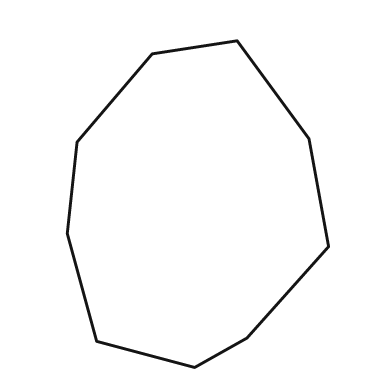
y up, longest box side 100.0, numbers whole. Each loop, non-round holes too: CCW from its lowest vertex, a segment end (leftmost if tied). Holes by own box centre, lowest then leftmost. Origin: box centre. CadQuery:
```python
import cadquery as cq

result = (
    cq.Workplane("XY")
    .moveTo(-1.0, -50.0)
    .lineTo(15.0, -41.0)
    .lineTo(40.0, -13.0)
    .lineTo(34.0, 20.0)
    .lineTo(12.0, 50.0)
    .lineTo(-14.0, 46.0)
    .lineTo(-37.0, 19.0)
    .lineTo(-40.0, -9.0)
    .lineTo(-31.0, -42.0)
    .close()
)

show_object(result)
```